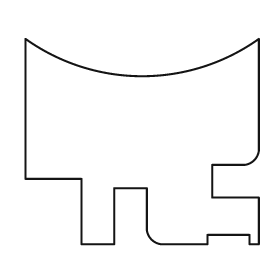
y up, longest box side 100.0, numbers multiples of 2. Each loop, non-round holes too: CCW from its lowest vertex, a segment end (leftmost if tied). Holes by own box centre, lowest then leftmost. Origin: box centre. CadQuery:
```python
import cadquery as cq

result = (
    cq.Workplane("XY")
    .moveTo(-26.0, -44.0)
    .lineTo(-12.0, -44.0)
    .lineTo(-12.0, -20.0)
    .lineTo(2.0, -20.0)
    .lineTo(2.0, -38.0)
    .threePointArc((4.0, -42.0), (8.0, -44.0))
    .lineTo(28.0, -44.0)
    .lineTo(28.0, -40.0)
    .lineTo(46.0, -40.0)
    .lineTo(46.0, -44.0)
    .lineTo(50.0, -44.0)
    .lineTo(50.0, -24.0)
    .lineTo(30.0, -24.0)
    .lineTo(30.0, -10.0)
    .lineTo(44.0, -10.0)
    .threePointArc((48.0, -8.0), (50.0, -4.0))
    .lineTo(50.0, 44.0)
    .threePointArc((0.0, 28.0), (-50.0, 44.0))
    .lineTo(-50.0, -16.0)
    .lineTo(-26.0, -16.0)
    .close()
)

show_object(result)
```